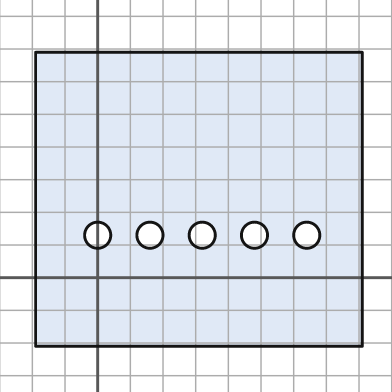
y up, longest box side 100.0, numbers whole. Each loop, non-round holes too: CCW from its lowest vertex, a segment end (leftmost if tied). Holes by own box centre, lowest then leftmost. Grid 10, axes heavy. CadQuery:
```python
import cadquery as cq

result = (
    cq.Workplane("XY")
    .moveTo(-19.0, -21.0)
    .lineTo(81.0, -21.0)
    .lineTo(81.0, 69.0)
    .lineTo(-19.0, 69.0)
    .close()
    .moveTo(0.0, 13.0)
    .circle(4.0)
    .moveTo(16.0, 13.0)
    .circle(4.0)
    .moveTo(32.0, 13.0)
    .circle(4.0)
    .moveTo(48.0, 13.0)
    .circle(4.0)
    .moveTo(64.0, 13.0)
    .circle(4.0)
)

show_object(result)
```